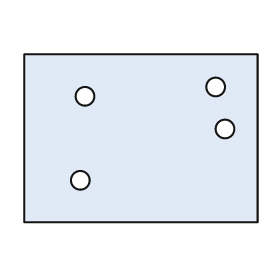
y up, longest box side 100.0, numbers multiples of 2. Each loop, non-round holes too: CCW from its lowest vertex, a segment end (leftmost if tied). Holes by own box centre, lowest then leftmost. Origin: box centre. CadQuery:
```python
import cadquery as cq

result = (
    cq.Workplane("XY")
    .moveTo(-50.0, -36.0)
    .lineTo(50.0, -36.0)
    .lineTo(50.0, 36.0)
    .lineTo(-50.0, 36.0)
    .close()
    .moveTo(-26.0, -18.0)
    .circle(4.0)
    .moveTo(36.0, 4.0)
    .circle(4.0)
    .moveTo(-24.0, 18.0)
    .circle(4.0)
    .moveTo(32.0, 22.0)
    .circle(4.0)
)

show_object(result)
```